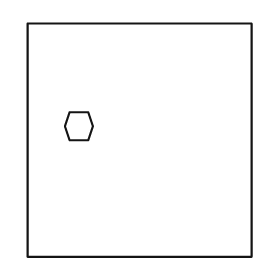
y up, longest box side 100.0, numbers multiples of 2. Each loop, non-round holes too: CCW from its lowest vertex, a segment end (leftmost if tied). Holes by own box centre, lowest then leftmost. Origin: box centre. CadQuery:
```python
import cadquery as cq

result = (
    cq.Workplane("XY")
    .moveTo(-48.0, -50.0)
    .lineTo(48.0, -50.0)
    .lineTo(48.0, 50.0)
    .lineTo(-48.0, 50.0)
    .close()
    .moveTo(-30.0, 0.0)
    .lineTo(-22.0, 0.0)
    .lineTo(-20.0, 6.0)
    .lineTo(-22.0, 12.0)
    .lineTo(-30.0, 12.0)
    .lineTo(-32.0, 6.0)
    .close()
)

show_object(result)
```